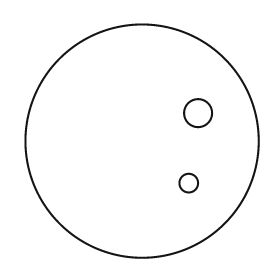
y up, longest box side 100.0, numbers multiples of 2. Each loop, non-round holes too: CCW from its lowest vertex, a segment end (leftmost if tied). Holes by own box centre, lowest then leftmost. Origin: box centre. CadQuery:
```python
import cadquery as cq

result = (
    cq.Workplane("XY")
    .moveTo(0.0, 0.0)
    .circle(50.0)
    .moveTo(20.0, -18.0)
    .circle(4.0)
    .moveTo(24.0, 12.0)
    .circle(6.0)
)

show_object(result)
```